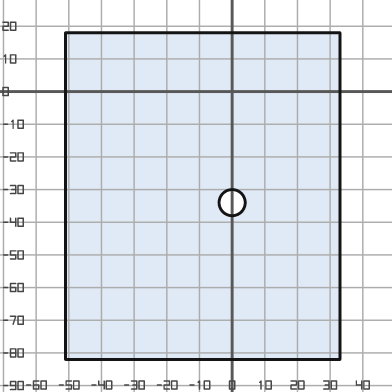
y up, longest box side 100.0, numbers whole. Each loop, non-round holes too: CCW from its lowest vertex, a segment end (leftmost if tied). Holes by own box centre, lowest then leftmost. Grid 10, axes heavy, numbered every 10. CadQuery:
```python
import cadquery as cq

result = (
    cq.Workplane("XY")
    .moveTo(-51.0, -82.0)
    .lineTo(33.0, -82.0)
    .lineTo(33.0, 18.0)
    .lineTo(-51.0, 18.0)
    .close()
    .moveTo(0.0, -34.0)
    .circle(4.0)
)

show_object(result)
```